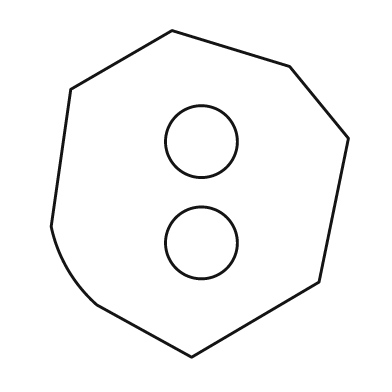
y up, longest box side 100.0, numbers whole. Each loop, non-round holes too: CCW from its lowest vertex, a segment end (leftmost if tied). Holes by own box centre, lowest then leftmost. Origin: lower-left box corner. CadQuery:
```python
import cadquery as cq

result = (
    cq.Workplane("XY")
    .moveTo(43.0, 0.0)
    .lineTo(82.0, 23.0)
    .lineTo(91.0, 67.0)
    .lineTo(73.0, 89.0)
    .lineTo(37.0, 100.0)
    .lineTo(6.0, 82.0)
    .lineTo(0.0, 40.0)
    .threePointArc((5.0, 27.0), (14.0, 16.0))
    .close()
    .moveTo(46.0, 35.0)
    .circle(11.0)
    .moveTo(46.0, 66.0)
    .circle(11.0)
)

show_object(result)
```